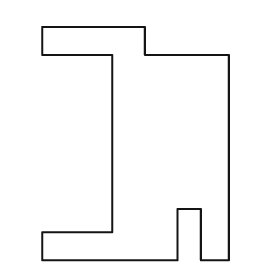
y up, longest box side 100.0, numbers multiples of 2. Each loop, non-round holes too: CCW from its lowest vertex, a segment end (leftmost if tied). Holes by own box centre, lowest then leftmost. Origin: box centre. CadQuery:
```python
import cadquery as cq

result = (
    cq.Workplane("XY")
    .moveTo(-40.0, -50.0)
    .lineTo(18.0, -50.0)
    .lineTo(18.0, -28.0)
    .lineTo(28.0, -28.0)
    .lineTo(28.0, -50.0)
    .lineTo(40.0, -50.0)
    .lineTo(40.0, 38.0)
    .lineTo(4.0, 38.0)
    .lineTo(4.0, 50.0)
    .lineTo(-40.0, 50.0)
    .lineTo(-40.0, 38.0)
    .lineTo(-10.0, 38.0)
    .lineTo(-10.0, -38.0)
    .lineTo(-40.0, -38.0)
    .close()
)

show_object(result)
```